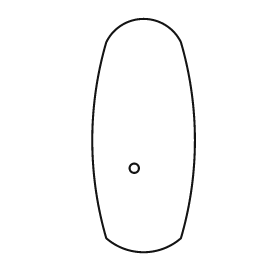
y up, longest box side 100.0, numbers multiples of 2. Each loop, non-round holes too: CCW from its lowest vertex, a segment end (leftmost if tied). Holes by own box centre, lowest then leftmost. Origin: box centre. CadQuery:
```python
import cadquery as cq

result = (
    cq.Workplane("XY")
    .moveTo(-16.0, -44.0)
    .threePointArc((0.0, -50.0), (16.0, -44.0))
    .threePointArc((22.0, -2.0), (16.0, 40.0))
    .threePointArc((0.0, 50.0), (-16.0, 40.0))
    .threePointArc((-22.0, -2.0), (-16.0, -44.0))
    .close()
    .moveTo(-4.0, -14.0)
    .circle(2.0)
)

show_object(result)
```